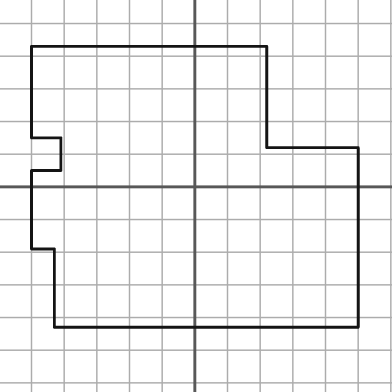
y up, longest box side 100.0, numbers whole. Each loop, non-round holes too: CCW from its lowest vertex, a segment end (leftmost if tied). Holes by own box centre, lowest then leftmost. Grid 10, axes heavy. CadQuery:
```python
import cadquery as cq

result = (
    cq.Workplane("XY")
    .moveTo(-43.0, -43.0)
    .lineTo(50.0, -43.0)
    .lineTo(50.0, 12.0)
    .lineTo(22.0, 12.0)
    .lineTo(22.0, 43.0)
    .lineTo(-50.0, 43.0)
    .lineTo(-50.0, 15.0)
    .lineTo(-41.0, 15.0)
    .lineTo(-41.0, 5.0)
    .lineTo(-50.0, 5.0)
    .lineTo(-50.0, -19.0)
    .lineTo(-43.0, -19.0)
    .close()
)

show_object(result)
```